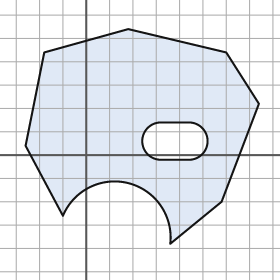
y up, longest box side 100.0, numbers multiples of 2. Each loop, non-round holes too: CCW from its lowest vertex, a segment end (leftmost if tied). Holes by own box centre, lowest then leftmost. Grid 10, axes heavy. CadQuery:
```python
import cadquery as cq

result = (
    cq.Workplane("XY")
    .moveTo(36.0, -38.0)
    .lineTo(58.0, -20.0)
    .lineTo(74.0, 22.0)
    .lineTo(60.0, 44.0)
    .lineTo(18.0, 54.0)
    .lineTo(-18.0, 44.0)
    .lineTo(-26.0, 4.0)
    .lineTo(-10.0, -26.0)
    .threePointArc((18.0, -12.0), (36.0, -38.0))
    .close()
    .moveTo(32.0, -2.0)
    .lineTo(44.0, -2.0)
    .threePointArc((52.0, 6.0), (44.0, 14.0))
    .lineTo(32.0, 14.0)
    .threePointArc((24.0, 6.0), (32.0, -2.0))
    .close()
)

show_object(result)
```